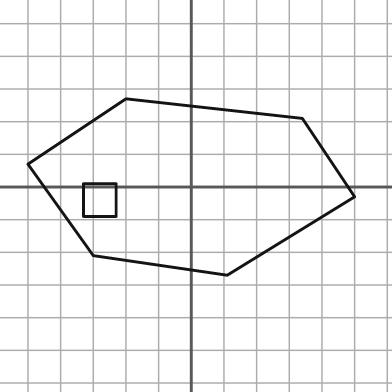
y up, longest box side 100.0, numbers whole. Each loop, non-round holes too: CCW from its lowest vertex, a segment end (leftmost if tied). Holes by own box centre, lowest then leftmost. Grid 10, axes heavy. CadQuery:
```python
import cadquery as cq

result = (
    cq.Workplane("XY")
    .moveTo(11.0, -27.0)
    .lineTo(50.0, -3.0)
    .lineTo(34.0, 21.0)
    .lineTo(-20.0, 27.0)
    .lineTo(-50.0, 7.0)
    .lineTo(-30.0, -21.0)
    .close()
    .moveTo(-33.0, -9.0)
    .lineTo(-23.0, -9.0)
    .lineTo(-23.0, 1.0)
    .lineTo(-33.0, 1.0)
    .close()
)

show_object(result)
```